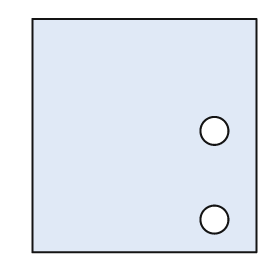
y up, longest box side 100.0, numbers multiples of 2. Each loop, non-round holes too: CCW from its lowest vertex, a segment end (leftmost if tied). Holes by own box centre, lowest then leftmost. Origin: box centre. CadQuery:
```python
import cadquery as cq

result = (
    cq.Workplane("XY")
    .moveTo(-48.0, -50.0)
    .lineTo(48.0, -50.0)
    .lineTo(48.0, 50.0)
    .lineTo(-48.0, 50.0)
    .close()
    .moveTo(30.0, -36.0)
    .circle(6.0)
    .moveTo(30.0, 2.0)
    .circle(6.0)
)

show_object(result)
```